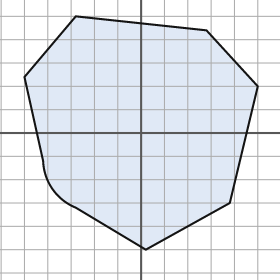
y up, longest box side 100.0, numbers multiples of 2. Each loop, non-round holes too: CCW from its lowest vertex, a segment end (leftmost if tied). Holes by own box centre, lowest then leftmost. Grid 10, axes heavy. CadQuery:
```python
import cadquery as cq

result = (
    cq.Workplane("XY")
    .moveTo(2.0, -50.0)
    .lineTo(38.0, -30.0)
    .lineTo(50.0, 20.0)
    .lineTo(28.0, 44.0)
    .lineTo(-28.0, 50.0)
    .lineTo(-50.0, 24.0)
    .lineTo(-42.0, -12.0)
    .threePointArc((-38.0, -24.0), (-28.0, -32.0))
    .close()
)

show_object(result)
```